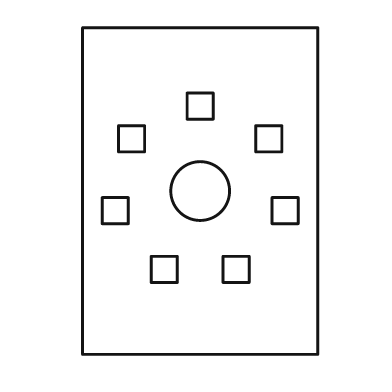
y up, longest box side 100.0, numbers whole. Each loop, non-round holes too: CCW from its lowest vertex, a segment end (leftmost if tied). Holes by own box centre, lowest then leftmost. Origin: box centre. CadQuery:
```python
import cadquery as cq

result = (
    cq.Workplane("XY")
    .moveTo(-36.0, -50.0)
    .lineTo(36.0, -50.0)
    .lineTo(36.0, 50.0)
    .lineTo(-36.0, 50.0)
    .close()
    .moveTo(-15.0, -28.0)
    .lineTo(-7.0, -28.0)
    .lineTo(-7.0, -20.0)
    .lineTo(-15.0, -20.0)
    .close()
    .moveTo(7.0, -28.0)
    .lineTo(15.0, -28.0)
    .lineTo(15.0, -20.0)
    .lineTo(7.0, -20.0)
    .close()
    .moveTo(-30.0, -10.0)
    .lineTo(-22.0, -10.0)
    .lineTo(-22.0, -2.0)
    .lineTo(-30.0, -2.0)
    .close()
    .moveTo(22.0, -10.0)
    .lineTo(30.0, -10.0)
    .lineTo(30.0, -2.0)
    .lineTo(22.0, -2.0)
    .close()
    .moveTo(0.0, 0.0)
    .circle(9.0)
    .moveTo(-25.0, 12.0)
    .lineTo(-17.0, 12.0)
    .lineTo(-17.0, 20.0)
    .lineTo(-25.0, 20.0)
    .close()
    .moveTo(17.0, 12.0)
    .lineTo(25.0, 12.0)
    .lineTo(25.0, 20.0)
    .lineTo(17.0, 20.0)
    .close()
    .moveTo(-4.0, 22.0)
    .lineTo(4.0, 22.0)
    .lineTo(4.0, 30.0)
    .lineTo(-4.0, 30.0)
    .close()
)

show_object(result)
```